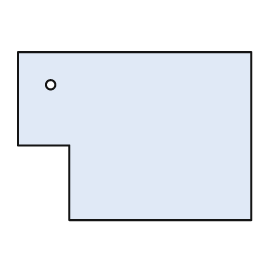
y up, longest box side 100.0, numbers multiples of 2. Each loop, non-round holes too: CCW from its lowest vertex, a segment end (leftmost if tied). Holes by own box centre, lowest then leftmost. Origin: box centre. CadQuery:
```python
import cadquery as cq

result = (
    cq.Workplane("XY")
    .moveTo(-28.0, -36.0)
    .lineTo(50.0, -36.0)
    .lineTo(50.0, 36.0)
    .lineTo(-50.0, 36.0)
    .lineTo(-50.0, -4.0)
    .lineTo(-28.0, -4.0)
    .close()
    .moveTo(-36.0, 22.0)
    .circle(2.0)
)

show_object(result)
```